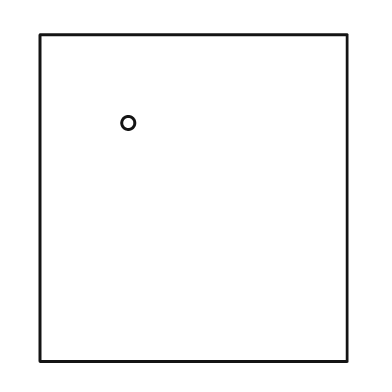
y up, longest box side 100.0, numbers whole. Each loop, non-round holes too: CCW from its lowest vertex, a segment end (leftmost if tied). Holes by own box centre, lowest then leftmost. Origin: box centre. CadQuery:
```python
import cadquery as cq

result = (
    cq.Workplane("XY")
    .moveTo(-47.0, -50.0)
    .lineTo(47.0, -50.0)
    .lineTo(47.0, 50.0)
    .lineTo(-47.0, 50.0)
    .close()
    .moveTo(-20.0, 23.0)
    .circle(2.0)
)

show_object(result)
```